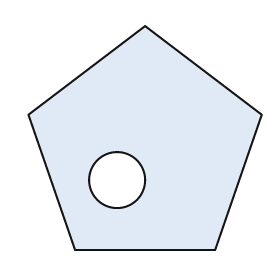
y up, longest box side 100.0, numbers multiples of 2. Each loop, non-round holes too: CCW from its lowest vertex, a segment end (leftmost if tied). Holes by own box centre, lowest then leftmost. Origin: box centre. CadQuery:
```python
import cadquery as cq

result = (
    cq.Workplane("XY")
    .moveTo(-30.0, -48.0)
    .lineTo(30.0, -48.0)
    .lineTo(50.0, 10.0)
    .lineTo(0.0, 48.0)
    .lineTo(-50.0, 10.0)
    .close()
    .moveTo(-12.0, -18.0)
    .circle(12.0)
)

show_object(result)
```